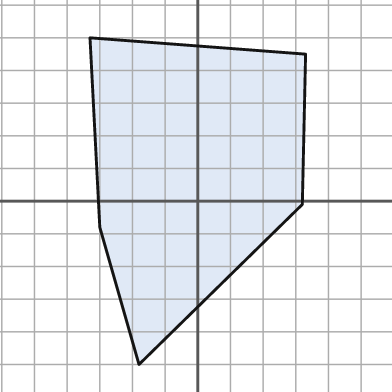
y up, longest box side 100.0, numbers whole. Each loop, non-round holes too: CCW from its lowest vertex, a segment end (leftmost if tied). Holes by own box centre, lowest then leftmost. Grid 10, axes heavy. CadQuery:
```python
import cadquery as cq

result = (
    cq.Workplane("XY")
    .moveTo(-18.0, -50.0)
    .lineTo(32.0, -1.0)
    .lineTo(33.0, 45.0)
    .lineTo(-33.0, 50.0)
    .lineTo(-30.0, -8.0)
    .close()
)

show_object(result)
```